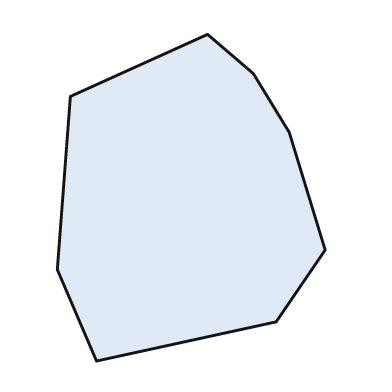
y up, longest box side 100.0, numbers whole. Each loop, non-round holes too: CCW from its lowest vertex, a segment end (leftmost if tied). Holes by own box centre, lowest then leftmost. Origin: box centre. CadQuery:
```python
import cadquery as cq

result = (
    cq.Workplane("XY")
    .moveTo(-29.0, -50.0)
    .lineTo(26.0, -38.0)
    .lineTo(41.0, -16.0)
    .lineTo(30.0, 20.0)
    .lineTo(19.0, 38.0)
    .lineTo(5.0, 50.0)
    .lineTo(-37.0, 31.0)
    .lineTo(-41.0, -22.0)
    .close()
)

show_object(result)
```